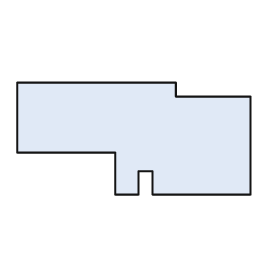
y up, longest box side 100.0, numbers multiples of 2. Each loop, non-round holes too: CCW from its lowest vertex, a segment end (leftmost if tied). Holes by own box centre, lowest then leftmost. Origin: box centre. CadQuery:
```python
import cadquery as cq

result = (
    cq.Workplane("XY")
    .moveTo(-8.0, -24.0)
    .lineTo(2.0, -24.0)
    .lineTo(2.0, -14.0)
    .lineTo(8.0, -14.0)
    .lineTo(8.0, -24.0)
    .lineTo(50.0, -24.0)
    .lineTo(50.0, 18.0)
    .lineTo(18.0, 18.0)
    .lineTo(18.0, 24.0)
    .lineTo(-50.0, 24.0)
    .lineTo(-50.0, -6.0)
    .lineTo(-8.0, -6.0)
    .close()
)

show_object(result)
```